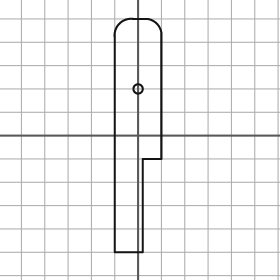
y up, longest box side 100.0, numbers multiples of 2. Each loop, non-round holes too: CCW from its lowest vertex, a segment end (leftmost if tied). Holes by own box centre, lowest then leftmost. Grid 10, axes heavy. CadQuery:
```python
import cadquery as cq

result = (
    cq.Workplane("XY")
    .moveTo(-10.0, -50.0)
    .lineTo(2.0, -50.0)
    .lineTo(2.0, -10.0)
    .lineTo(10.0, -10.0)
    .lineTo(10.0, 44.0)
    .threePointArc((8.0, 48.0), (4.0, 50.0))
    .lineTo(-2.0, 50.0)
    .threePointArc((-8.0, 48.0), (-10.0, 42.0))
    .close()
    .moveTo(0.0, 20.0)
    .circle(2.0)
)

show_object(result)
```